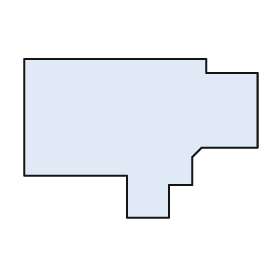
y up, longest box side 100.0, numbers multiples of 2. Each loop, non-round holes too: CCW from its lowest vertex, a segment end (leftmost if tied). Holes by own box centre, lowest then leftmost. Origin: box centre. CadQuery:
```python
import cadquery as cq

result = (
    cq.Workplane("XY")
    .moveTo(-6.0, -34.0)
    .lineTo(12.0, -34.0)
    .lineTo(12.0, -20.0)
    .lineTo(22.0, -20.0)
    .lineTo(22.0, -8.0)
    .lineTo(26.0, -4.0)
    .lineTo(50.0, -4.0)
    .lineTo(50.0, 28.0)
    .lineTo(28.0, 28.0)
    .lineTo(28.0, 34.0)
    .lineTo(-50.0, 34.0)
    .lineTo(-50.0, -16.0)
    .lineTo(-6.0, -16.0)
    .close()
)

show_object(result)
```